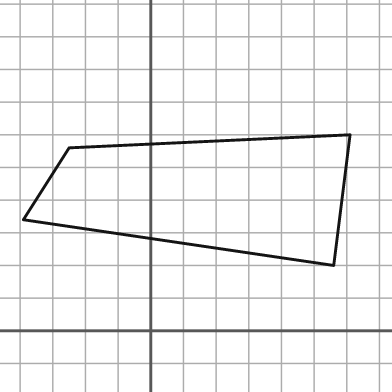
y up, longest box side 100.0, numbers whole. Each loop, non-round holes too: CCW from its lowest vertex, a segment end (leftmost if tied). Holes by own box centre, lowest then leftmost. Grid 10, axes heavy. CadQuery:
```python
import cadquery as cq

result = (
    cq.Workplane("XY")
    .moveTo(56.0, 20.0)
    .lineTo(61.0, 60.0)
    .lineTo(-25.0, 56.0)
    .lineTo(-39.0, 34.0)
    .close()
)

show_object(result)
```